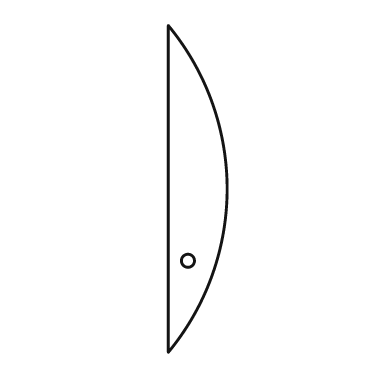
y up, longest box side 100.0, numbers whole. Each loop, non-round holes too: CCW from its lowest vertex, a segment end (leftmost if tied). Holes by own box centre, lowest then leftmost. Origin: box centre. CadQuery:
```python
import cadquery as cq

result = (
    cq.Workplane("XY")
    .moveTo(-9.0, -50.0)
    .threePointArc((9.0, 0.0), (-9.0, 50.0))
    .close()
    .moveTo(-3.0, -22.0)
    .circle(2.0)
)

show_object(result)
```